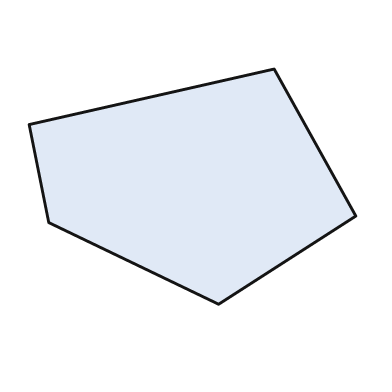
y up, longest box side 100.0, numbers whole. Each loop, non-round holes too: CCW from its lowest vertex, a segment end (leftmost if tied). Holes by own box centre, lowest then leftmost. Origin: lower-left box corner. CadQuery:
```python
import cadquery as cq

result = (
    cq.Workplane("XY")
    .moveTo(58.0, 0.0)
    .lineTo(100.0, 27.0)
    .lineTo(75.0, 72.0)
    .lineTo(0.0, 55.0)
    .lineTo(6.0, 25.0)
    .close()
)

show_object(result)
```